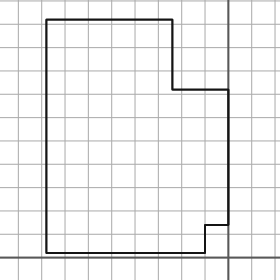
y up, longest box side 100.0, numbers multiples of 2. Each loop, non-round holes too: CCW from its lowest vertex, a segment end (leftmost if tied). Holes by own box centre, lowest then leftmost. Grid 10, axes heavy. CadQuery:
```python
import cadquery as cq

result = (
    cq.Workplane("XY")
    .moveTo(-78.0, 2.0)
    .lineTo(-10.0, 2.0)
    .lineTo(-10.0, 14.0)
    .lineTo(0.0, 14.0)
    .lineTo(0.0, 72.0)
    .lineTo(-24.0, 72.0)
    .lineTo(-24.0, 102.0)
    .lineTo(-78.0, 102.0)
    .close()
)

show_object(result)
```